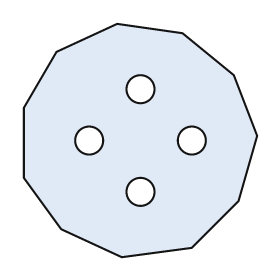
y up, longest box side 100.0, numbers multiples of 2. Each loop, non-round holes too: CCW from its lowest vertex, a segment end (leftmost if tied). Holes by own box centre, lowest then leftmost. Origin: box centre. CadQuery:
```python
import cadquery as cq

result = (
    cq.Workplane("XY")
    .moveTo(-8.0, -50.0)
    .lineTo(22.0, -46.0)
    .lineTo(42.0, -26.0)
    .lineTo(50.0, 2.0)
    .lineTo(40.0, 28.0)
    .lineTo(18.0, 46.0)
    .lineTo(-10.0, 50.0)
    .lineTo(-36.0, 38.0)
    .lineTo(-50.0, 14.0)
    .lineTo(-50.0, -16.0)
    .lineTo(-34.0, -38.0)
    .close()
    .moveTo(0.0, -22.0)
    .circle(6.0)
    .moveTo(-22.0, 0.0)
    .circle(6.0)
    .moveTo(22.0, 0.0)
    .circle(6.0)
    .moveTo(0.0, 22.0)
    .circle(6.0)
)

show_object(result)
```